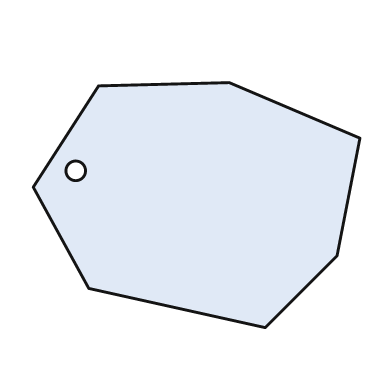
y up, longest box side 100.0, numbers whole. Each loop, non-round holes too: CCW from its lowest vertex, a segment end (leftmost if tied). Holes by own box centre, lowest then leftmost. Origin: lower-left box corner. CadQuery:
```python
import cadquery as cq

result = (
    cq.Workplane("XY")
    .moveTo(71.0, 0.0)
    .lineTo(93.0, 22.0)
    .lineTo(100.0, 58.0)
    .lineTo(60.0, 75.0)
    .lineTo(20.0, 74.0)
    .lineTo(0.0, 43.0)
    .lineTo(17.0, 12.0)
    .close()
    .moveTo(13.0, 48.0)
    .circle(3.0)
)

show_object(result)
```